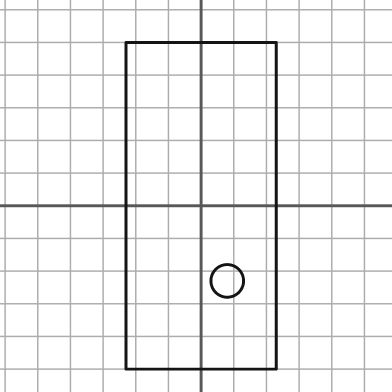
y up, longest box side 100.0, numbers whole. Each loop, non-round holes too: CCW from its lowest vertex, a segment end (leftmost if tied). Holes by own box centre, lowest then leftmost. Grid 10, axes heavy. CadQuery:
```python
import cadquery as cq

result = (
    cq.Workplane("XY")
    .moveTo(-23.0, -50.0)
    .lineTo(23.0, -50.0)
    .lineTo(23.0, 50.0)
    .lineTo(-23.0, 50.0)
    .close()
    .moveTo(8.0, -23.0)
    .circle(5.0)
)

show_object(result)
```